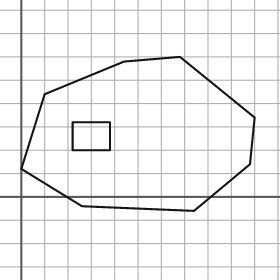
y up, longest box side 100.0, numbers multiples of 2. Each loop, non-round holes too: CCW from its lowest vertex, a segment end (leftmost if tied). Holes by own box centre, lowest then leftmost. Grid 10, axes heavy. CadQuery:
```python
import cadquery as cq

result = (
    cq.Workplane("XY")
    .moveTo(74.0, -6.0)
    .lineTo(98.0, 14.0)
    .lineTo(100.0, 34.0)
    .lineTo(68.0, 60.0)
    .lineTo(44.0, 58.0)
    .lineTo(10.0, 44.0)
    .lineTo(0.0, 12.0)
    .lineTo(26.0, -4.0)
    .close()
    .moveTo(22.0, 20.0)
    .lineTo(38.0, 20.0)
    .lineTo(38.0, 32.0)
    .lineTo(22.0, 32.0)
    .close()
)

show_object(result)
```